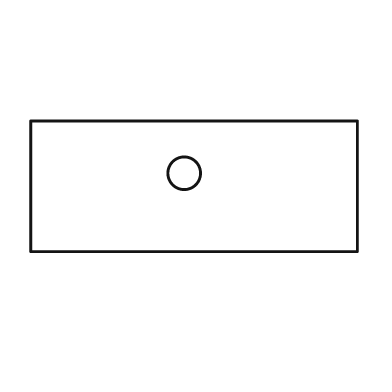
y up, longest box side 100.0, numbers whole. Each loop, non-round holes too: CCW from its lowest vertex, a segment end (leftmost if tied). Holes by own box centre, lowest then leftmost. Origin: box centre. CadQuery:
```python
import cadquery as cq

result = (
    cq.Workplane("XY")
    .moveTo(-50.0, -20.0)
    .lineTo(50.0, -20.0)
    .lineTo(50.0, 20.0)
    .lineTo(-50.0, 20.0)
    .close()
    .moveTo(-3.0, 4.0)
    .circle(5.0)
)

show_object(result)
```